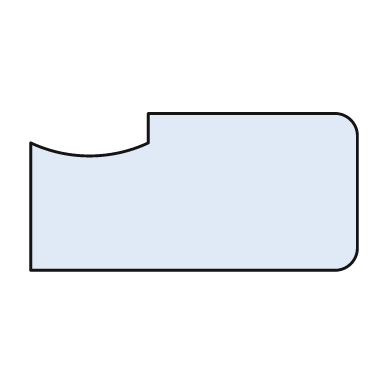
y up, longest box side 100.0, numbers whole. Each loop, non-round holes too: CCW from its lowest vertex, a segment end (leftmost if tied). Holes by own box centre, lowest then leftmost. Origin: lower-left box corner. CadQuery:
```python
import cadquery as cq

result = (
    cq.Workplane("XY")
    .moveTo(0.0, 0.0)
    .lineTo(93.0, 0.0)
    .threePointArc((98.0, 2.0), (100.0, 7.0))
    .lineTo(100.0, 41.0)
    .threePointArc((98.0, 46.0), (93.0, 48.0))
    .lineTo(36.0, 48.0)
    .lineTo(36.0, 39.0)
    .threePointArc((18.0, 35.0), (0.0, 39.0))
    .close()
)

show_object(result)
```